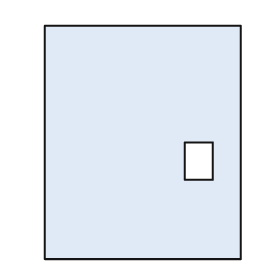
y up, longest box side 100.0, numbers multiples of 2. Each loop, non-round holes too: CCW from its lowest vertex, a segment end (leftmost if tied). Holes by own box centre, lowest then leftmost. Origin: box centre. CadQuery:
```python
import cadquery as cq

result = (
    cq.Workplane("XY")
    .moveTo(-42.0, -50.0)
    .lineTo(42.0, -50.0)
    .lineTo(42.0, 50.0)
    .lineTo(-42.0, 50.0)
    .close()
    .moveTo(18.0, -16.0)
    .lineTo(30.0, -16.0)
    .lineTo(30.0, 0.0)
    .lineTo(18.0, 0.0)
    .close()
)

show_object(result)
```